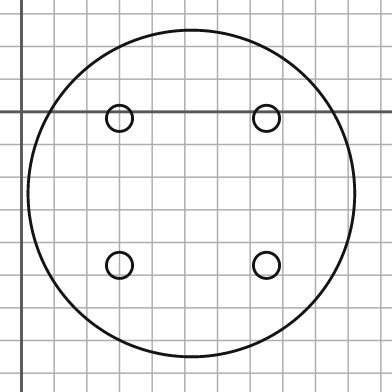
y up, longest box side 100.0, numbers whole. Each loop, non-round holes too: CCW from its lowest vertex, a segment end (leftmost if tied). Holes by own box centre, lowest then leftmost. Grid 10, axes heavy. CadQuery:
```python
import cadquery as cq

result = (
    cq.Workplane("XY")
    .moveTo(52.0, -25.0)
    .circle(50.0)
    .moveTo(30.0, -47.0)
    .circle(4.0)
    .moveTo(75.0, -47.0)
    .circle(4.0)
    .moveTo(30.0, -2.0)
    .circle(4.0)
    .moveTo(75.0, -2.0)
    .circle(4.0)
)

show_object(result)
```